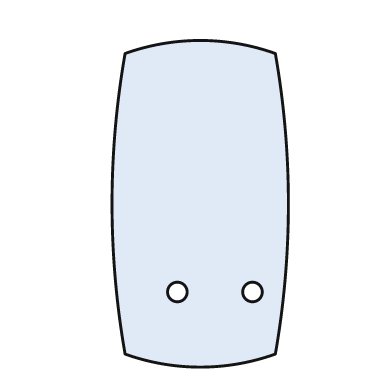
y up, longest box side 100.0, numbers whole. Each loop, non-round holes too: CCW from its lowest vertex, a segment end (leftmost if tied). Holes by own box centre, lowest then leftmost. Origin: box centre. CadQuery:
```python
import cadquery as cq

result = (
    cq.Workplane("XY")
    .moveTo(-23.0, -46.0)
    .threePointArc((0.0, -50.0), (23.0, -46.0))
    .threePointArc((27.0, 0.0), (23.0, 46.0))
    .threePointArc((0.0, 50.0), (-23.0, 46.0))
    .threePointArc((-27.0, 0.0), (-23.0, -46.0))
    .close()
    .moveTo(-7.0, -27.0)
    .circle(3.0)
    .moveTo(16.0, -27.0)
    .circle(3.0)
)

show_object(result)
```